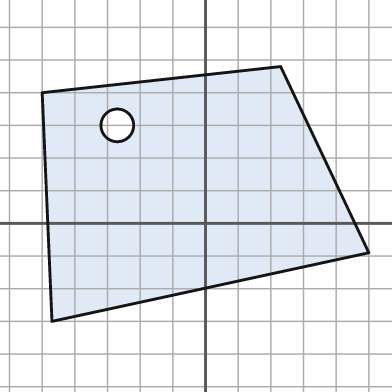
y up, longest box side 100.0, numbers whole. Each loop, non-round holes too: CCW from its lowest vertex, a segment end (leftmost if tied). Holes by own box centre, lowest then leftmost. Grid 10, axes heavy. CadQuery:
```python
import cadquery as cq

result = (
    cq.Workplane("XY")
    .moveTo(-47.0, -30.0)
    .lineTo(50.0, -9.0)
    .lineTo(23.0, 48.0)
    .lineTo(-50.0, 40.0)
    .close()
    .moveTo(-27.0, 30.0)
    .circle(5.0)
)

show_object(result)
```